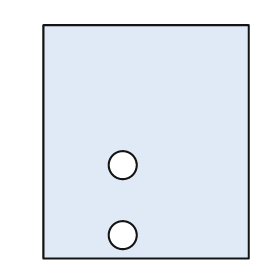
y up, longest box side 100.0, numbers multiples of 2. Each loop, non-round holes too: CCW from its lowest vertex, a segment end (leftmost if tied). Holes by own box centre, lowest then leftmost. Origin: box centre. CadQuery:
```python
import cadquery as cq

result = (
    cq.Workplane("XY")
    .moveTo(-44.0, -50.0)
    .lineTo(44.0, -50.0)
    .lineTo(44.0, 50.0)
    .lineTo(-44.0, 50.0)
    .close()
    .moveTo(-10.0, -40.0)
    .circle(6.0)
    .moveTo(-10.0, -10.0)
    .circle(6.0)
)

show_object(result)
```